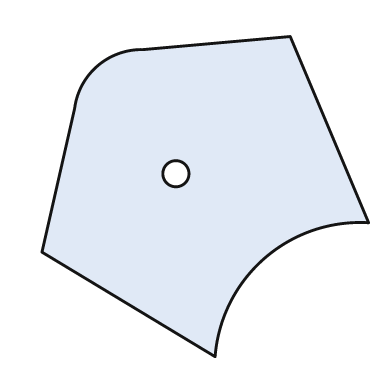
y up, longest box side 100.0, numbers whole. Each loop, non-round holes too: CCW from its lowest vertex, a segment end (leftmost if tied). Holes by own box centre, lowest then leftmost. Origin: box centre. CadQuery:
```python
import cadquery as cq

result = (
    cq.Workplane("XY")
    .moveTo(3.0, -49.0)
    .threePointArc((18.0, -19.0), (50.0, -8.0))
    .lineTo(26.0, 49.0)
    .lineTo(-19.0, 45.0)
    .threePointArc((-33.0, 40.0), (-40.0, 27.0))
    .lineTo(-50.0, -17.0)
    .close()
    .moveTo(-9.0, 7.0)
    .circle(4.0)
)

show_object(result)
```